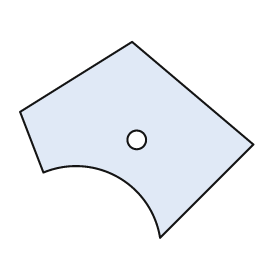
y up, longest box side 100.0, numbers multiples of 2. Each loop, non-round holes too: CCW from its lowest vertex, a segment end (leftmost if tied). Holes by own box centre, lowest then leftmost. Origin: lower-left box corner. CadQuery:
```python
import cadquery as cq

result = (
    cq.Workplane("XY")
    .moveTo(60.0, 0.0)
    .lineTo(100.0, 40.0)
    .lineTo(48.0, 84.0)
    .lineTo(0.0, 54.0)
    .lineTo(10.0, 28.0)
    .threePointArc((42.0, 26.0), (60.0, 0.0))
    .close()
    .moveTo(50.0, 42.0)
    .circle(4.0)
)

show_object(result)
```